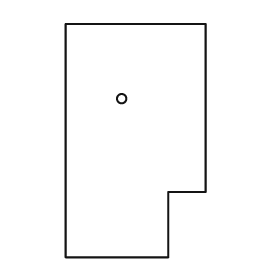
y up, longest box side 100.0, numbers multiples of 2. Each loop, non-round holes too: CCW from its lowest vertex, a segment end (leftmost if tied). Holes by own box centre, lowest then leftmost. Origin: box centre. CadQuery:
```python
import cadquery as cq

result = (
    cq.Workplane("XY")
    .moveTo(-30.0, -50.0)
    .lineTo(14.0, -50.0)
    .lineTo(14.0, -22.0)
    .lineTo(30.0, -22.0)
    .lineTo(30.0, 50.0)
    .lineTo(-30.0, 50.0)
    .close()
    .moveTo(-6.0, 18.0)
    .circle(2.0)
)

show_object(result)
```